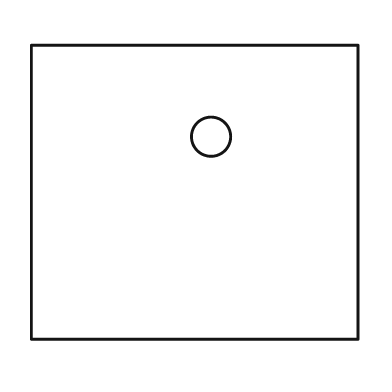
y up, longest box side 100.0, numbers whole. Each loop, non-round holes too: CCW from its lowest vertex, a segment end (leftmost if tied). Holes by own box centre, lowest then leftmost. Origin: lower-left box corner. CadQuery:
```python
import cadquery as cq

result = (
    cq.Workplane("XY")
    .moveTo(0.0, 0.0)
    .lineTo(100.0, 0.0)
    .lineTo(100.0, 90.0)
    .lineTo(0.0, 90.0)
    .close()
    .moveTo(55.0, 62.0)
    .circle(6.0)
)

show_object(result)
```